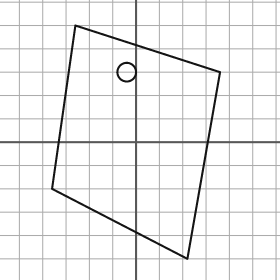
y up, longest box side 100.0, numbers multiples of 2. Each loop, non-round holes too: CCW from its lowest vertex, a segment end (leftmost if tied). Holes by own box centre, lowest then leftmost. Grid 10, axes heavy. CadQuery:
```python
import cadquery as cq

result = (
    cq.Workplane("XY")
    .moveTo(22.0, -50.0)
    .lineTo(36.0, 30.0)
    .lineTo(-26.0, 50.0)
    .lineTo(-36.0, -20.0)
    .close()
    .moveTo(-4.0, 30.0)
    .circle(4.0)
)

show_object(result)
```